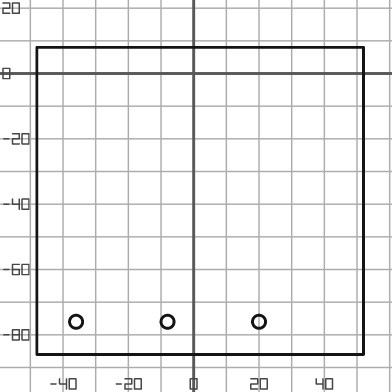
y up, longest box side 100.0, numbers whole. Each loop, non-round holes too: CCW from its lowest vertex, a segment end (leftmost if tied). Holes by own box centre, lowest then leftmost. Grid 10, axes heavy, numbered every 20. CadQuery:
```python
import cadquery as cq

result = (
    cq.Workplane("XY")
    .moveTo(-48.0, -86.0)
    .lineTo(52.0, -86.0)
    .lineTo(52.0, 8.0)
    .lineTo(-48.0, 8.0)
    .close()
    .moveTo(-36.0, -76.0)
    .circle(2.0)
    .moveTo(-8.0, -76.0)
    .circle(2.0)
    .moveTo(20.0, -76.0)
    .circle(2.0)
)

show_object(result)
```